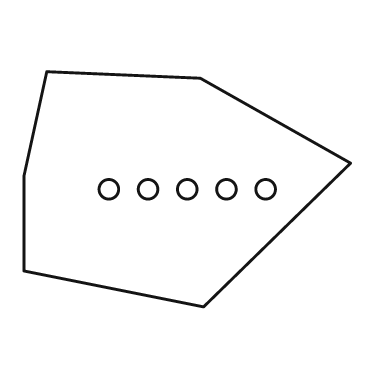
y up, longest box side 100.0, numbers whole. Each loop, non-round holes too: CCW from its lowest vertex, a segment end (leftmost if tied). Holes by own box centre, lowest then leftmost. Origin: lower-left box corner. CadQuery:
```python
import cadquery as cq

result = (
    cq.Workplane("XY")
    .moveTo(55.0, 0.0)
    .lineTo(100.0, 44.0)
    .lineTo(54.0, 70.0)
    .lineTo(7.0, 72.0)
    .lineTo(0.0, 40.0)
    .lineTo(0.0, 11.0)
    .close()
    .moveTo(26.0, 36.0)
    .circle(3.0)
    .moveTo(38.0, 36.0)
    .circle(3.0)
    .moveTo(50.0, 36.0)
    .circle(3.0)
    .moveTo(62.0, 36.0)
    .circle(3.0)
    .moveTo(74.0, 36.0)
    .circle(3.0)
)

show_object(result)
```